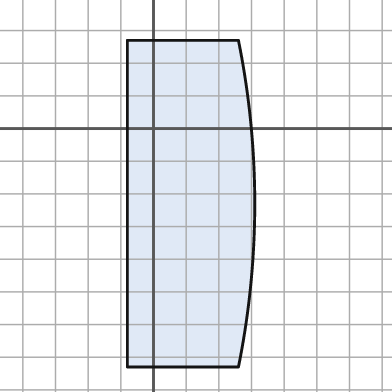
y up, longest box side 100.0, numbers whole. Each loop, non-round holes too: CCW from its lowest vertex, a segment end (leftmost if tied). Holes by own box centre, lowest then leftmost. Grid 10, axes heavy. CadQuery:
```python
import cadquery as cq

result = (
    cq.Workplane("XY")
    .moveTo(-8.0, -73.0)
    .lineTo(26.0, -73.0)
    .threePointArc((31.0, -23.0), (26.0, 27.0))
    .lineTo(-8.0, 27.0)
    .close()
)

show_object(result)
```